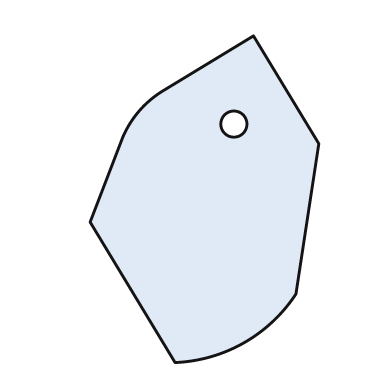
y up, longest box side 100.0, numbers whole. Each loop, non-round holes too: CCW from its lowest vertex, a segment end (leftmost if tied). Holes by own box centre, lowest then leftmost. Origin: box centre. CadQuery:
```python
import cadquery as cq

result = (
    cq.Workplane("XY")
    .moveTo(-9.0, -50.0)
    .threePointArc((12.0, -44.0), (28.0, -29.0))
    .lineTo(35.0, 17.0)
    .lineTo(15.0, 50.0)
    .lineTo(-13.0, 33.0)
    .threePointArc((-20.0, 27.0), (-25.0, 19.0))
    .lineTo(-35.0, -7.0)
    .close()
    .moveTo(9.0, 23.0)
    .circle(4.0)
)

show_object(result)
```